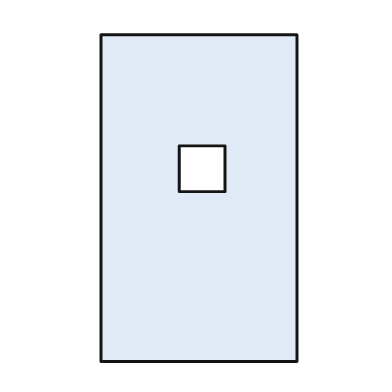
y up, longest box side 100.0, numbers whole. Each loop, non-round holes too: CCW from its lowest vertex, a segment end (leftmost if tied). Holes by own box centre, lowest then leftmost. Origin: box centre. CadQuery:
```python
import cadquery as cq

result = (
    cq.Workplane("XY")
    .moveTo(-30.0, -50.0)
    .lineTo(30.0, -50.0)
    .lineTo(30.0, 50.0)
    .lineTo(-30.0, 50.0)
    .close()
    .moveTo(-6.0, 2.0)
    .lineTo(8.0, 2.0)
    .lineTo(8.0, 16.0)
    .lineTo(-6.0, 16.0)
    .close()
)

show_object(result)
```